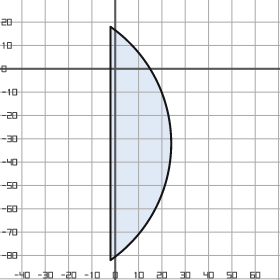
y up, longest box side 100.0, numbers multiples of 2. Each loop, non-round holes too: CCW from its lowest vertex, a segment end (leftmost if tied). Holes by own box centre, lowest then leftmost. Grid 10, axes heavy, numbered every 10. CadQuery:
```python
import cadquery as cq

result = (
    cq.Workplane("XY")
    .moveTo(-2.0, -82.0)
    .threePointArc((24.0, -32.0), (-2.0, 18.0))
    .close()
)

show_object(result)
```